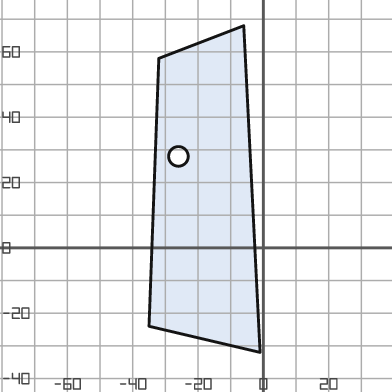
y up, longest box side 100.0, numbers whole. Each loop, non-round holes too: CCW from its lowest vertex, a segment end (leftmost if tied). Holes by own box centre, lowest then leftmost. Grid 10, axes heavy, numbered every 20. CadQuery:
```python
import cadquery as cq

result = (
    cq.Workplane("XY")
    .moveTo(-1.0, -32.0)
    .lineTo(-6.0, 68.0)
    .lineTo(-32.0, 58.0)
    .lineTo(-35.0, -24.0)
    .close()
    .moveTo(-26.0, 28.0)
    .circle(3.0)
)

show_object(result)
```